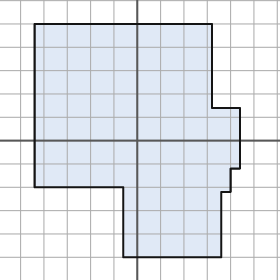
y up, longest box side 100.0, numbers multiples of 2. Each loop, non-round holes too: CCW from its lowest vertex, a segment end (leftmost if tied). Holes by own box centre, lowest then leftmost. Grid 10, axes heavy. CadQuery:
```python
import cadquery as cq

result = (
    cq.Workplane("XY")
    .moveTo(-6.0, -50.0)
    .lineTo(36.0, -50.0)
    .lineTo(36.0, -22.0)
    .lineTo(40.0, -22.0)
    .lineTo(40.0, -12.0)
    .lineTo(44.0, -12.0)
    .lineTo(44.0, 14.0)
    .lineTo(32.0, 14.0)
    .lineTo(32.0, 50.0)
    .lineTo(-44.0, 50.0)
    .lineTo(-44.0, -20.0)
    .lineTo(-6.0, -20.0)
    .close()
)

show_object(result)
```